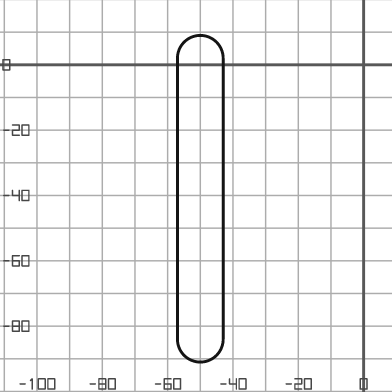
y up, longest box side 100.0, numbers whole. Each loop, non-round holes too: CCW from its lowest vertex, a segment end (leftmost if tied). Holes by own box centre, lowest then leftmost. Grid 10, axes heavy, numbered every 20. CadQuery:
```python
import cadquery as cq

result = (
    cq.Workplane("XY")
    .moveTo(-57.0, -84.0)
    .threePointArc((-50.0, -91.0), (-43.0, -84.0))
    .lineTo(-43.0, 2.0)
    .threePointArc((-50.0, 9.0), (-57.0, 2.0))
    .close()
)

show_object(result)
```